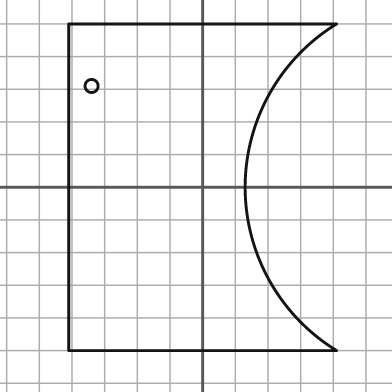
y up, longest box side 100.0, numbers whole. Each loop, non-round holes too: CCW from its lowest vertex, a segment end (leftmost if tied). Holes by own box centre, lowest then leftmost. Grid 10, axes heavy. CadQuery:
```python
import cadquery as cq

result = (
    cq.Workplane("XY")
    .moveTo(-41.0, -50.0)
    .lineTo(41.0, -50.0)
    .threePointArc((13.0, 0.0), (41.0, 50.0))
    .lineTo(-41.0, 50.0)
    .close()
    .moveTo(-34.0, 31.0)
    .circle(2.0)
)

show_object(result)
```